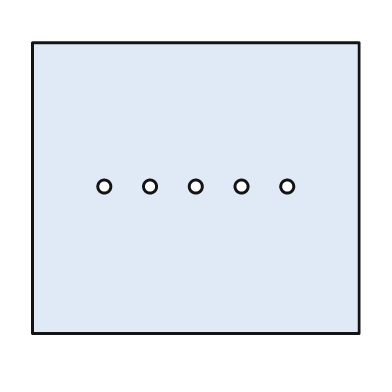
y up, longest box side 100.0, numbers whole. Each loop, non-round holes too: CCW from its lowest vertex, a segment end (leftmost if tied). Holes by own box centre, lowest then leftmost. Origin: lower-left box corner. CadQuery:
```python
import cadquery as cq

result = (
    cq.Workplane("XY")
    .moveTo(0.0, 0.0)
    .lineTo(100.0, 0.0)
    .lineTo(100.0, 89.0)
    .lineTo(0.0, 89.0)
    .close()
    .moveTo(22.0, 45.0)
    .circle(2.0)
    .moveTo(36.0, 45.0)
    .circle(2.0)
    .moveTo(50.0, 45.0)
    .circle(2.0)
    .moveTo(64.0, 45.0)
    .circle(2.0)
    .moveTo(78.0, 45.0)
    .circle(2.0)
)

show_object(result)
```